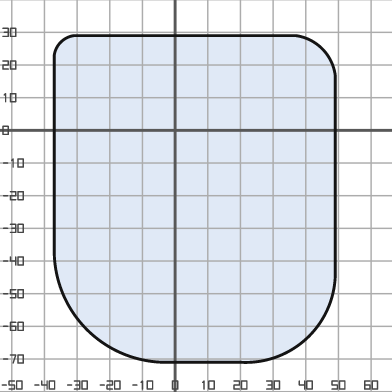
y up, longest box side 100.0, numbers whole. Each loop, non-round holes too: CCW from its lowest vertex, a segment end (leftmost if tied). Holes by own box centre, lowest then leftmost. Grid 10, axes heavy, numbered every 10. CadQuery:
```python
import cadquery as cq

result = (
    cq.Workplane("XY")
    .moveTo(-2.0, -71.0)
    .lineTo(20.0, -71.0)
    .threePointArc((41.0, -63.0), (49.0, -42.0))
    .lineTo(49.0, 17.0)
    .threePointArc((45.0, 25.0), (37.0, 29.0))
    .lineTo(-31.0, 29.0)
    .threePointArc((-35.0, 27.0), (-37.0, 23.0))
    .lineTo(-37.0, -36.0)
    .threePointArc((-27.0, -61.0), (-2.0, -71.0))
    .close()
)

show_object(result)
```